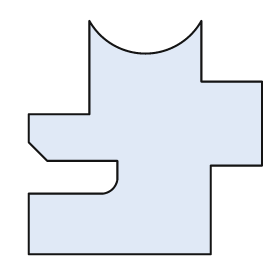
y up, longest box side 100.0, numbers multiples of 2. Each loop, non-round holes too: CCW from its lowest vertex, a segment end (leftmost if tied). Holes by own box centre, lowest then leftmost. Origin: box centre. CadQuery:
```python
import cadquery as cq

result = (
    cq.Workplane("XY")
    .moveTo(-50.0, -50.0)
    .lineTo(28.0, -50.0)
    .lineTo(28.0, -12.0)
    .lineTo(50.0, -12.0)
    .lineTo(50.0, 24.0)
    .lineTo(24.0, 24.0)
    .lineTo(24.0, 50.0)
    .threePointArc((0.0, 36.0), (-24.0, 50.0))
    .lineTo(-24.0, 10.0)
    .lineTo(-50.0, 10.0)
    .lineTo(-50.0, -2.0)
    .lineTo(-42.0, -10.0)
    .lineTo(-12.0, -10.0)
    .lineTo(-12.0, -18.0)
    .threePointArc((-14.0, -22.0), (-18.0, -24.0))
    .lineTo(-50.0, -24.0)
    .close()
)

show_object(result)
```